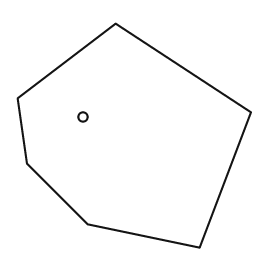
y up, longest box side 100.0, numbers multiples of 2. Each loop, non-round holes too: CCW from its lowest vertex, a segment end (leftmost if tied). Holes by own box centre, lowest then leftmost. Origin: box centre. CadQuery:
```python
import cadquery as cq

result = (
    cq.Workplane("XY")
    .moveTo(28.0, -48.0)
    .lineTo(50.0, 10.0)
    .lineTo(-8.0, 48.0)
    .lineTo(-50.0, 16.0)
    .lineTo(-46.0, -12.0)
    .lineTo(-20.0, -38.0)
    .close()
    .moveTo(-22.0, 8.0)
    .circle(2.0)
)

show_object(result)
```